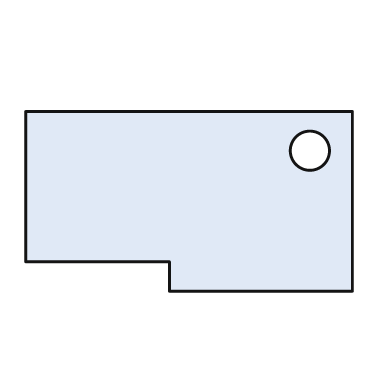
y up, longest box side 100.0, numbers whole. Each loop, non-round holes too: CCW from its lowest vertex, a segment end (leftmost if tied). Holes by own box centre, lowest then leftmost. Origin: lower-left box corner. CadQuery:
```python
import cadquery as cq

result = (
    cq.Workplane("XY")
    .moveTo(44.0, 0.0)
    .lineTo(100.0, 0.0)
    .lineTo(100.0, 55.0)
    .lineTo(0.0, 55.0)
    .lineTo(0.0, 9.0)
    .lineTo(44.0, 9.0)
    .close()
    .moveTo(87.0, 43.0)
    .circle(6.0)
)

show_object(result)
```